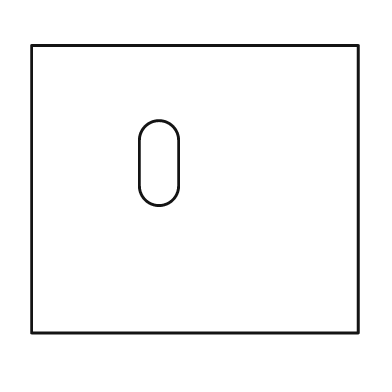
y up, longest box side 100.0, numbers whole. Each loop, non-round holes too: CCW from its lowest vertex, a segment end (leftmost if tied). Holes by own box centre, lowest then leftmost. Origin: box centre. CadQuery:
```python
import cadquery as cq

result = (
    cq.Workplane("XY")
    .moveTo(-50.0, -44.0)
    .lineTo(50.0, -44.0)
    .lineTo(50.0, 44.0)
    .lineTo(-50.0, 44.0)
    .close()
    .moveTo(-17.0, 1.0)
    .threePointArc((-11.0, -5.0), (-5.0, 1.0))
    .lineTo(-5.0, 15.0)
    .threePointArc((-11.0, 21.0), (-17.0, 15.0))
    .close()
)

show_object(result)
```